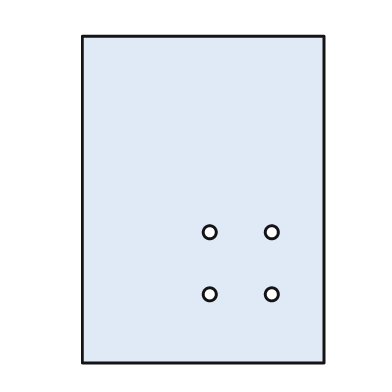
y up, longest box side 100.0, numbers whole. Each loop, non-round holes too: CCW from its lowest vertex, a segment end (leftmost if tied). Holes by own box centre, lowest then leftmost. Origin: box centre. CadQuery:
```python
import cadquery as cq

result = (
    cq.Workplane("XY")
    .moveTo(-37.0, -50.0)
    .lineTo(37.0, -50.0)
    .lineTo(37.0, 50.0)
    .lineTo(-37.0, 50.0)
    .close()
    .moveTo(2.0, -29.0)
    .circle(2.0)
    .moveTo(21.0, -29.0)
    .circle(2.0)
    .moveTo(2.0, -10.0)
    .circle(2.0)
    .moveTo(21.0, -10.0)
    .circle(2.0)
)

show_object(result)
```